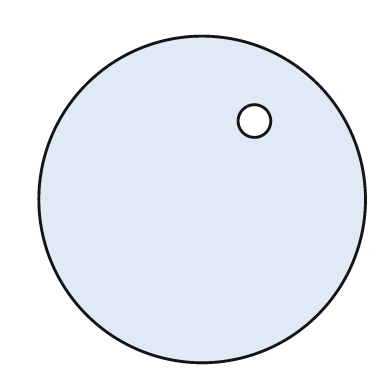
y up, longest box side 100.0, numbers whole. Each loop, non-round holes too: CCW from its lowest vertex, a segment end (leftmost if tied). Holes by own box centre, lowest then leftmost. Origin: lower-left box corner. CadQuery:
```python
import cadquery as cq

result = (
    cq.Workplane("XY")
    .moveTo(50.0, 50.0)
    .circle(50.0)
    .moveTo(66.0, 74.0)
    .circle(5.0)
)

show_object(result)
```